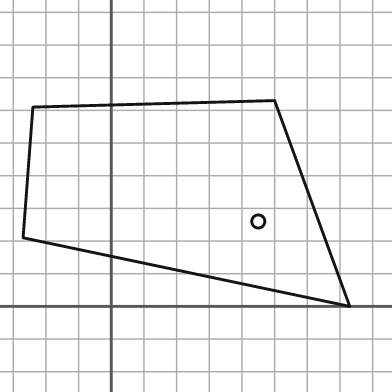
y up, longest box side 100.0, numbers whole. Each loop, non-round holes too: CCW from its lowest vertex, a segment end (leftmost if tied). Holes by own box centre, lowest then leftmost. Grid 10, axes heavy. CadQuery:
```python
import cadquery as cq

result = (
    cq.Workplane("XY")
    .moveTo(73.0, 0.0)
    .lineTo(50.0, 63.0)
    .lineTo(-24.0, 61.0)
    .lineTo(-27.0, 21.0)
    .close()
    .moveTo(45.0, 26.0)
    .circle(2.0)
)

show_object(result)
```